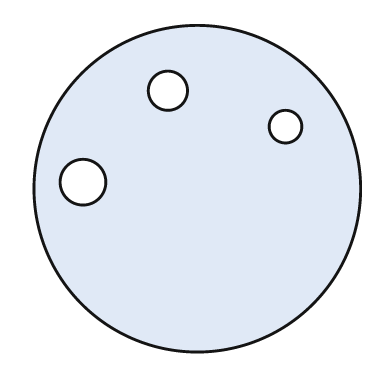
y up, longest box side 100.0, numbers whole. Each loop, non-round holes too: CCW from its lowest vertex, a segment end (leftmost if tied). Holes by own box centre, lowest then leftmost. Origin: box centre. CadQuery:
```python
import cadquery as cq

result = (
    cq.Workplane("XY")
    .moveTo(0.0, 0.0)
    .circle(50.0)
    .moveTo(-35.0, 2.0)
    .circle(7.0)
    .moveTo(27.0, 19.0)
    .circle(5.0)
    .moveTo(-9.0, 30.0)
    .circle(6.0)
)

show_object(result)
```